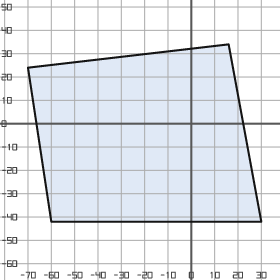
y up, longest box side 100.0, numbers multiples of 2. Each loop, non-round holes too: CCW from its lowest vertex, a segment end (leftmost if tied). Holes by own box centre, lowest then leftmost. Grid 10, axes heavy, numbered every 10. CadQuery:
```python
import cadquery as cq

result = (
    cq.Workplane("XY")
    .moveTo(-60.0, -42.0)
    .lineTo(30.0, -42.0)
    .lineTo(16.0, 34.0)
    .lineTo(-70.0, 24.0)
    .close()
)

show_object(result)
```